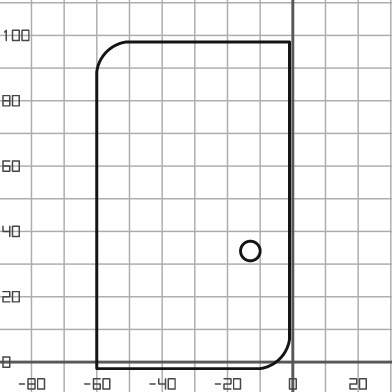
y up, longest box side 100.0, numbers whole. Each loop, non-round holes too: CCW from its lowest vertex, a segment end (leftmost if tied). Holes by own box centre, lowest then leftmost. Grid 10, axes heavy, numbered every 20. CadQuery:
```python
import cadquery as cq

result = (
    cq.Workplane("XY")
    .moveTo(-60.0, -2.0)
    .lineTo(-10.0, -2.0)
    .threePointArc((-4.0, 1.0), (-1.0, 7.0))
    .lineTo(-1.0, 98.0)
    .lineTo(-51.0, 98.0)
    .threePointArc((-57.0, 95.0), (-60.0, 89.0))
    .close()
    .moveTo(-13.0, 34.0)
    .circle(3.0)
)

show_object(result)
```